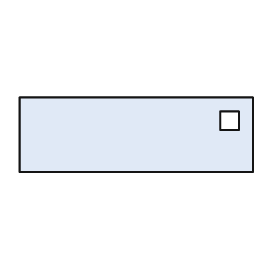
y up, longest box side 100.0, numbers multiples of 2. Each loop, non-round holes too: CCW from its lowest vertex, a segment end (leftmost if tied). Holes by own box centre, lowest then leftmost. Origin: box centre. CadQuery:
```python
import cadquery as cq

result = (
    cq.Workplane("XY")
    .moveTo(-50.0, -16.0)
    .lineTo(50.0, -16.0)
    .lineTo(50.0, 16.0)
    .lineTo(-50.0, 16.0)
    .close()
    .moveTo(36.0, 2.0)
    .lineTo(44.0, 2.0)
    .lineTo(44.0, 10.0)
    .lineTo(36.0, 10.0)
    .close()
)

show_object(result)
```